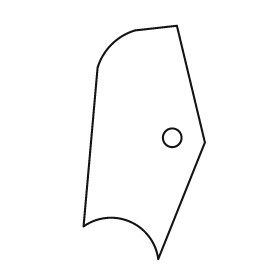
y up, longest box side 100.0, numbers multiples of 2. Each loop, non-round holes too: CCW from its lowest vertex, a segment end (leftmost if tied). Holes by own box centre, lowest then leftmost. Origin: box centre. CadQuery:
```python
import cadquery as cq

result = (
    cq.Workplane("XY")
    .moveTo(6.0, -50.0)
    .lineTo(26.0, 0.0)
    .lineTo(14.0, 50.0)
    .lineTo(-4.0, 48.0)
    .threePointArc((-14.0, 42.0), (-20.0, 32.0))
    .lineTo(-26.0, -36.0)
    .threePointArc((-6.0, -34.0), (6.0, -50.0))
    .close()
    .moveTo(12.0, 2.0)
    .circle(4.0)
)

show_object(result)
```